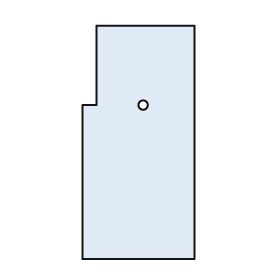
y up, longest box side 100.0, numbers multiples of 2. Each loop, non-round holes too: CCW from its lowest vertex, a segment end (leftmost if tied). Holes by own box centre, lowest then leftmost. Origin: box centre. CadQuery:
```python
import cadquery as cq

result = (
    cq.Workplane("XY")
    .moveTo(-24.0, -50.0)
    .lineTo(24.0, -50.0)
    .lineTo(24.0, 50.0)
    .lineTo(-18.0, 50.0)
    .lineTo(-18.0, 16.0)
    .lineTo(-24.0, 16.0)
    .close()
    .moveTo(2.0, 16.0)
    .circle(2.0)
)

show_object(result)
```